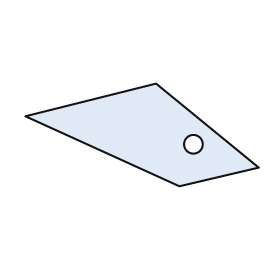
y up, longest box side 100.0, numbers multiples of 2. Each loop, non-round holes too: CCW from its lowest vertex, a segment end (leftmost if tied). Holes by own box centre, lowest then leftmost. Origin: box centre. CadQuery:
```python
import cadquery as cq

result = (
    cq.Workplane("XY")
    .moveTo(16.0, -22.0)
    .lineTo(50.0, -14.0)
    .lineTo(6.0, 22.0)
    .lineTo(-50.0, 8.0)
    .close()
    .moveTo(22.0, -4.0)
    .circle(4.0)
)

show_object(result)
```